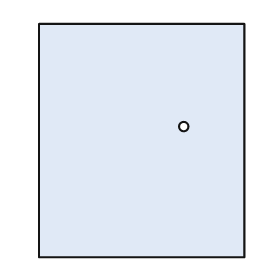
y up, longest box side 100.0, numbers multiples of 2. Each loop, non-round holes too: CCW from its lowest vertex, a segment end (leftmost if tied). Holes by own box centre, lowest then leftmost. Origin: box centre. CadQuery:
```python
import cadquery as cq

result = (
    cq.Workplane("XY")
    .moveTo(-44.0, -50.0)
    .lineTo(44.0, -50.0)
    .lineTo(44.0, 50.0)
    .lineTo(-44.0, 50.0)
    .close()
    .moveTo(18.0, 6.0)
    .circle(2.0)
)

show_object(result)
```